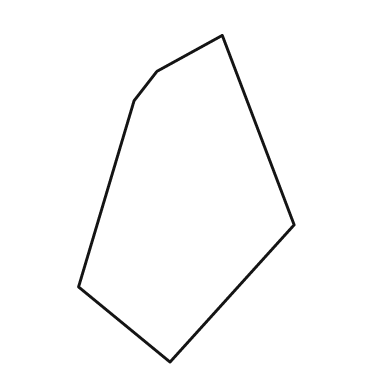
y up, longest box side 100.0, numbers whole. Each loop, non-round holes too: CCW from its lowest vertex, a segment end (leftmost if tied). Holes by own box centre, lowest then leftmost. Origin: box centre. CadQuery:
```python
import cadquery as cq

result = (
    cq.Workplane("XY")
    .moveTo(-5.0, -50.0)
    .lineTo(33.0, -8.0)
    .lineTo(11.0, 50.0)
    .lineTo(-9.0, 39.0)
    .lineTo(-16.0, 30.0)
    .lineTo(-33.0, -27.0)
    .close()
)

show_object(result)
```